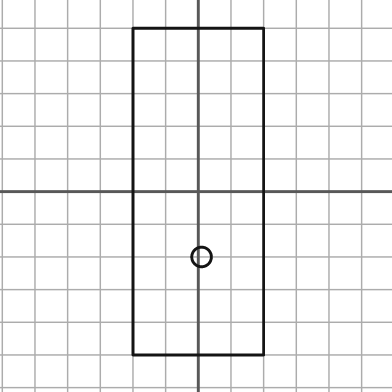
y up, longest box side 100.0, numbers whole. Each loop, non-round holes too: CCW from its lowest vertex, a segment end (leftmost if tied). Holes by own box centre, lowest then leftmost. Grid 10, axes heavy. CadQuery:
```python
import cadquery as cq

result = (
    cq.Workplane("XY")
    .moveTo(-20.0, -50.0)
    .lineTo(20.0, -50.0)
    .lineTo(20.0, 50.0)
    .lineTo(-20.0, 50.0)
    .close()
    .moveTo(1.0, -20.0)
    .circle(3.0)
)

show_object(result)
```